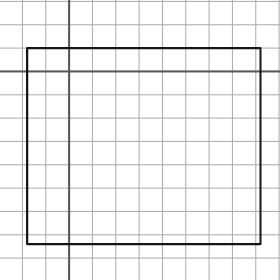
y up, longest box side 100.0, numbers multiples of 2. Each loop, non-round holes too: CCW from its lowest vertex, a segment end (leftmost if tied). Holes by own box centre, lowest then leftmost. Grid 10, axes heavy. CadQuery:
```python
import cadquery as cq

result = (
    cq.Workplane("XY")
    .moveTo(-18.0, -74.0)
    .lineTo(82.0, -74.0)
    .lineTo(82.0, 10.0)
    .lineTo(-18.0, 10.0)
    .close()
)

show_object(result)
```